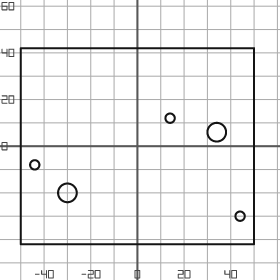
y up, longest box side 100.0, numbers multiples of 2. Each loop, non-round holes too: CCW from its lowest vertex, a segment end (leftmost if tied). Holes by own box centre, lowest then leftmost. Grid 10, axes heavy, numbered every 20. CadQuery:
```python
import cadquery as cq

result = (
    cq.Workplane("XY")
    .moveTo(-50.0, -42.0)
    .lineTo(50.0, -42.0)
    .lineTo(50.0, 42.0)
    .lineTo(-50.0, 42.0)
    .close()
    .moveTo(44.0, -30.0)
    .circle(2.0)
    .moveTo(-30.0, -20.0)
    .circle(4.0)
    .moveTo(-44.0, -8.0)
    .circle(2.0)
    .moveTo(34.0, 6.0)
    .circle(4.0)
    .moveTo(14.0, 12.0)
    .circle(2.0)
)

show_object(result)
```